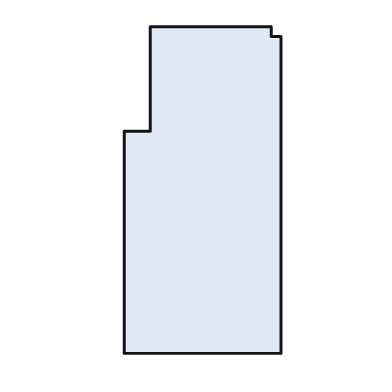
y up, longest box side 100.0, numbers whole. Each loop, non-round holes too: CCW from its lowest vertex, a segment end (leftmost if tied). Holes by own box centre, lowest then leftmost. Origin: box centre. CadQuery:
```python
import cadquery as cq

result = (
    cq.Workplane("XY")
    .moveTo(-24.0, -50.0)
    .lineTo(24.0, -50.0)
    .lineTo(24.0, 47.0)
    .lineTo(21.0, 47.0)
    .lineTo(21.0, 50.0)
    .lineTo(-16.0, 50.0)
    .lineTo(-16.0, 18.0)
    .lineTo(-24.0, 18.0)
    .close()
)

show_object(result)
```